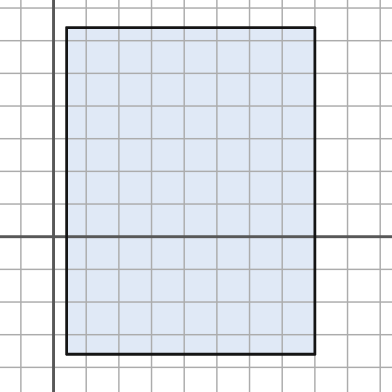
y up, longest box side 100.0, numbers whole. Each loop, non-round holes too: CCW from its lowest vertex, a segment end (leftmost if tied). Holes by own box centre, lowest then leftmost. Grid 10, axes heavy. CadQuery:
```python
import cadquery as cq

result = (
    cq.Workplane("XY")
    .moveTo(4.0, -36.0)
    .lineTo(80.0, -36.0)
    .lineTo(80.0, 64.0)
    .lineTo(4.0, 64.0)
    .close()
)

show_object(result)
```